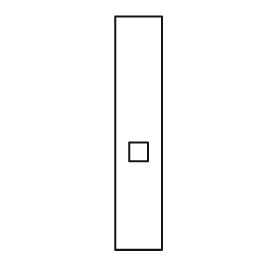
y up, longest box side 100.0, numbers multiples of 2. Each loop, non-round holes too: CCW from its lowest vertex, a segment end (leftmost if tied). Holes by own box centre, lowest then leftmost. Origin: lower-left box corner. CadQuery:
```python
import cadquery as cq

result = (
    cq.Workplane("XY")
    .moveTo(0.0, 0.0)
    .lineTo(20.0, 0.0)
    .lineTo(20.0, 100.0)
    .lineTo(0.0, 100.0)
    .close()
    .moveTo(6.0, 38.0)
    .lineTo(14.0, 38.0)
    .lineTo(14.0, 46.0)
    .lineTo(6.0, 46.0)
    .close()
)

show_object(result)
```